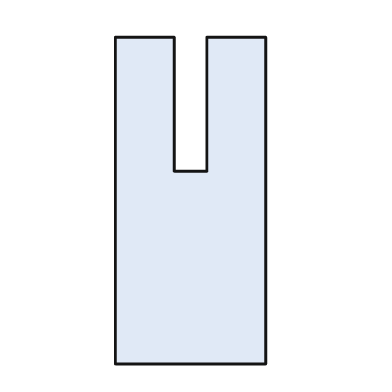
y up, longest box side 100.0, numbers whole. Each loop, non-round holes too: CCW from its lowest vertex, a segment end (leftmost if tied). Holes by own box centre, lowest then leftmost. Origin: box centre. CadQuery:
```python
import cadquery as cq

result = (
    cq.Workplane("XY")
    .moveTo(-23.0, -50.0)
    .lineTo(23.0, -50.0)
    .lineTo(23.0, 50.0)
    .lineTo(5.0, 50.0)
    .lineTo(5.0, 9.0)
    .lineTo(-5.0, 9.0)
    .lineTo(-5.0, 50.0)
    .lineTo(-23.0, 50.0)
    .close()
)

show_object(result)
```